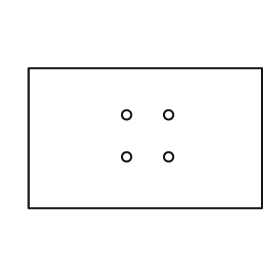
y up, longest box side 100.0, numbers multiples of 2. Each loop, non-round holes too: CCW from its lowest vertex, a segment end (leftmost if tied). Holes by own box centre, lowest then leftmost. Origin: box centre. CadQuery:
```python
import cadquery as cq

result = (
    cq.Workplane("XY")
    .moveTo(-50.0, -30.0)
    .lineTo(50.0, -30.0)
    .lineTo(50.0, 30.0)
    .lineTo(-50.0, 30.0)
    .close()
    .moveTo(-8.0, -8.0)
    .circle(2.0)
    .moveTo(10.0, -8.0)
    .circle(2.0)
    .moveTo(-8.0, 10.0)
    .circle(2.0)
    .moveTo(10.0, 10.0)
    .circle(2.0)
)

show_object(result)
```